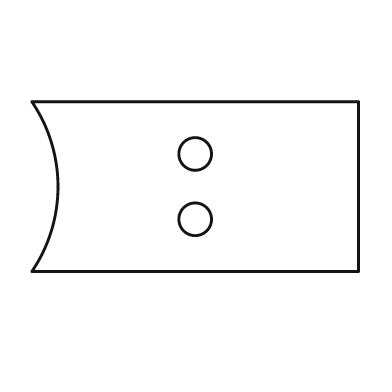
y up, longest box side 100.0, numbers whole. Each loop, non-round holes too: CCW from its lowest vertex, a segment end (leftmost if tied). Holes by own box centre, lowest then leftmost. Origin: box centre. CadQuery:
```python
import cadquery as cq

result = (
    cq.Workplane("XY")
    .moveTo(-50.0, -26.0)
    .lineTo(50.0, -26.0)
    .lineTo(50.0, 26.0)
    .lineTo(-50.0, 26.0)
    .threePointArc((-42.0, 0.0), (-50.0, -26.0))
    .close()
    .moveTo(0.0, -10.0)
    .circle(5.0)
    .moveTo(0.0, 10.0)
    .circle(5.0)
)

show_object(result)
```